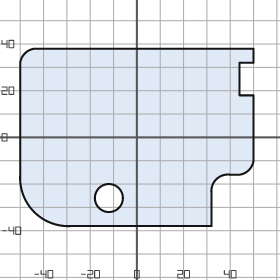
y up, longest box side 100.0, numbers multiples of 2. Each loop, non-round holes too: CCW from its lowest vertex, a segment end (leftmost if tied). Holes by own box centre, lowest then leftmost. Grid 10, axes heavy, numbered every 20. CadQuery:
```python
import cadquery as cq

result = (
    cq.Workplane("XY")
    .moveTo(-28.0, -38.0)
    .lineTo(32.0, -38.0)
    .lineTo(32.0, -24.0)
    .threePointArc((34.0, -18.0), (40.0, -16.0))
    .lineTo(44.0, -16.0)
    .threePointArc((48.0, -14.0), (50.0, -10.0))
    .lineTo(50.0, 18.0)
    .lineTo(44.0, 18.0)
    .lineTo(44.0, 32.0)
    .lineTo(50.0, 32.0)
    .lineTo(50.0, 38.0)
    .lineTo(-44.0, 38.0)
    .threePointArc((-48.0, 36.0), (-50.0, 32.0))
    .lineTo(-50.0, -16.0)
    .threePointArc((-44.0, -32.0), (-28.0, -38.0))
    .close()
    .moveTo(-12.0, -26.0)
    .circle(6.0)
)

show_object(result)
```